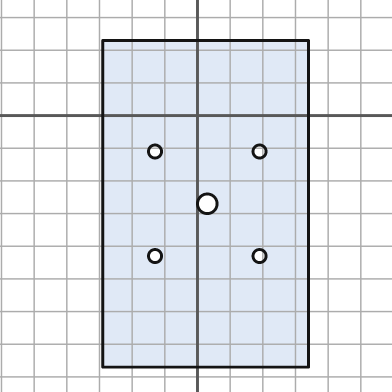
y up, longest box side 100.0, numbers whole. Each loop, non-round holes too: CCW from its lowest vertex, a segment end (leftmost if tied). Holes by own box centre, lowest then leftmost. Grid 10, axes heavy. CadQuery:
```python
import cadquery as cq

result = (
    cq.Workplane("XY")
    .moveTo(-29.0, -77.0)
    .lineTo(34.0, -77.0)
    .lineTo(34.0, 23.0)
    .lineTo(-29.0, 23.0)
    .close()
    .moveTo(-13.0, -43.0)
    .circle(2.0)
    .moveTo(19.0, -43.0)
    .circle(2.0)
    .moveTo(3.0, -27.0)
    .circle(3.0)
    .moveTo(-13.0, -11.0)
    .circle(2.0)
    .moveTo(19.0, -11.0)
    .circle(2.0)
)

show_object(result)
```